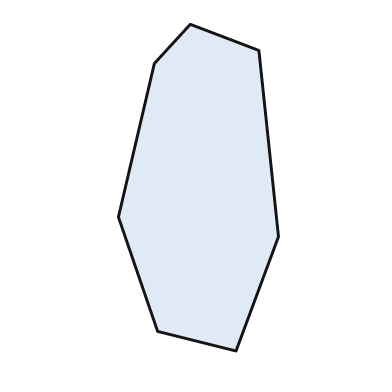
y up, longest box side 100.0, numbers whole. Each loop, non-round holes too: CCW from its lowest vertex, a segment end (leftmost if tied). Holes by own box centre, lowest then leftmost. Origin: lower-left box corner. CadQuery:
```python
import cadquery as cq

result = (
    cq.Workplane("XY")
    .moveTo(36.0, 0.0)
    .lineTo(49.0, 35.0)
    .lineTo(43.0, 92.0)
    .lineTo(22.0, 100.0)
    .lineTo(11.0, 88.0)
    .lineTo(0.0, 41.0)
    .lineTo(12.0, 6.0)
    .close()
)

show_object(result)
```